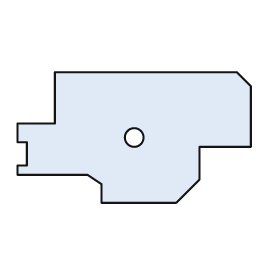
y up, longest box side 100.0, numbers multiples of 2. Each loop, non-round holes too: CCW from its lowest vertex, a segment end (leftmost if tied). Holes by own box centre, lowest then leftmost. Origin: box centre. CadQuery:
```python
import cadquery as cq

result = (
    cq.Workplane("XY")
    .moveTo(-14.0, -28.0)
    .lineTo(18.0, -28.0)
    .lineTo(28.0, -18.0)
    .lineTo(28.0, -4.0)
    .lineTo(50.0, -4.0)
    .lineTo(50.0, 22.0)
    .lineTo(44.0, 28.0)
    .lineTo(-34.0, 28.0)
    .lineTo(-34.0, 6.0)
    .lineTo(-50.0, 6.0)
    .lineTo(-50.0, -2.0)
    .lineTo(-46.0, -2.0)
    .lineTo(-46.0, -12.0)
    .lineTo(-50.0, -12.0)
    .lineTo(-50.0, -16.0)
    .lineTo(-20.0, -16.0)
    .lineTo(-14.0, -20.0)
    .close()
    .moveTo(0.0, 0.0)
    .circle(4.0)
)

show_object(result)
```